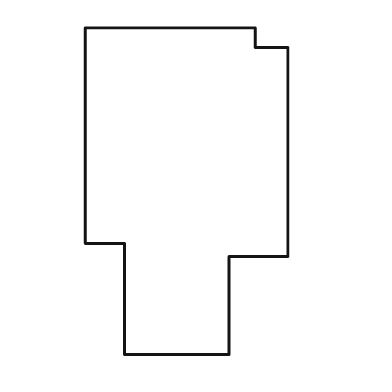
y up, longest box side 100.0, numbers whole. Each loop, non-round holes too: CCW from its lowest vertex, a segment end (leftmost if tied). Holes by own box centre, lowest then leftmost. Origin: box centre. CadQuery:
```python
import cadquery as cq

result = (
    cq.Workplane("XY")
    .moveTo(-19.0, -50.0)
    .lineTo(13.0, -50.0)
    .lineTo(13.0, -20.0)
    .lineTo(31.0, -20.0)
    .lineTo(31.0, 44.0)
    .lineTo(21.0, 44.0)
    .lineTo(21.0, 50.0)
    .lineTo(-31.0, 50.0)
    .lineTo(-31.0, -16.0)
    .lineTo(-19.0, -16.0)
    .close()
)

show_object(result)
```